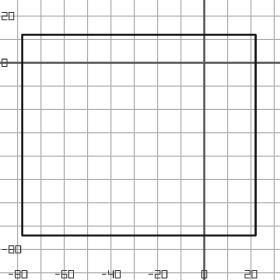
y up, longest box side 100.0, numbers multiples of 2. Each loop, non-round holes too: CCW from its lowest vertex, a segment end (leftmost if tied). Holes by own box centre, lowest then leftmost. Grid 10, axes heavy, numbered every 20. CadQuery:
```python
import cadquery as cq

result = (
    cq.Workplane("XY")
    .moveTo(-78.0, -74.0)
    .lineTo(22.0, -74.0)
    .lineTo(22.0, 12.0)
    .lineTo(-78.0, 12.0)
    .close()
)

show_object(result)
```